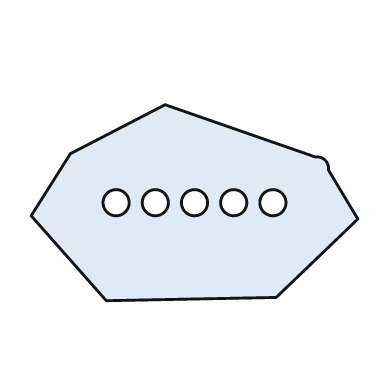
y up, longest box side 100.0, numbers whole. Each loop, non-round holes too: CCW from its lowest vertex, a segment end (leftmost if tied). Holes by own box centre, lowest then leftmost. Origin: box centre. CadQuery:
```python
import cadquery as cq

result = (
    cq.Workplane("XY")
    .moveTo(-27.0, -30.0)
    .lineTo(25.0, -29.0)
    .lineTo(50.0, -5.0)
    .lineTo(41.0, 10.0)
    .threePointArc((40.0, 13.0), (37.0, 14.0))
    .lineTo(-9.0, 30.0)
    .lineTo(-38.0, 15.0)
    .lineTo(-50.0, -4.0)
    .close()
    .moveTo(-24.0, 0.0)
    .circle(4.0)
    .moveTo(-12.0, 0.0)
    .circle(4.0)
    .moveTo(0.0, 0.0)
    .circle(4.0)
    .moveTo(12.0, 0.0)
    .circle(4.0)
    .moveTo(24.0, 0.0)
    .circle(4.0)
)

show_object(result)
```